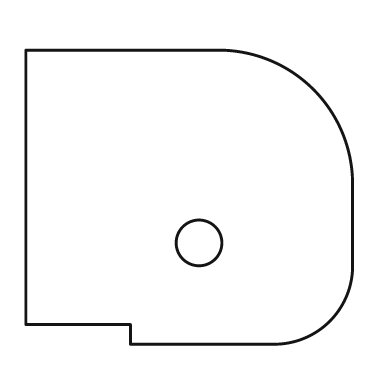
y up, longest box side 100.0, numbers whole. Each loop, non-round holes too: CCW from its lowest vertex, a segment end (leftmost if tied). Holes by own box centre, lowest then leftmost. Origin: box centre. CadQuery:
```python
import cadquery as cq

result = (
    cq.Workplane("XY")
    .moveTo(-18.0, -45.0)
    .lineTo(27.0, -45.0)
    .threePointArc((43.0, -38.0), (50.0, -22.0))
    .lineTo(50.0, 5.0)
    .threePointArc((38.0, 33.0), (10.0, 45.0))
    .lineTo(-50.0, 45.0)
    .lineTo(-50.0, -39.0)
    .lineTo(-18.0, -39.0)
    .close()
    .moveTo(3.0, -14.0)
    .circle(7.0)
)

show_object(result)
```